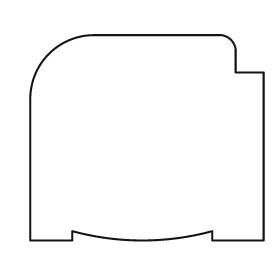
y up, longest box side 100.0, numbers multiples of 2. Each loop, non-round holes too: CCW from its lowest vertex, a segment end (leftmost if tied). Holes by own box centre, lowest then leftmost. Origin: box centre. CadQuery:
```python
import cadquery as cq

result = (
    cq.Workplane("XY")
    .moveTo(-50.0, -44.0)
    .lineTo(-32.0, -44.0)
    .lineTo(-32.0, -40.0)
    .threePointArc((-2.0, -44.0), (28.0, -40.0))
    .lineTo(28.0, -44.0)
    .lineTo(50.0, -44.0)
    .lineTo(50.0, 28.0)
    .lineTo(38.0, 28.0)
    .lineTo(38.0, 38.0)
    .threePointArc((36.0, 42.0), (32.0, 44.0))
    .lineTo(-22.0, 44.0)
    .threePointArc((-42.0, 36.0), (-50.0, 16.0))
    .close()
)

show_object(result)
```